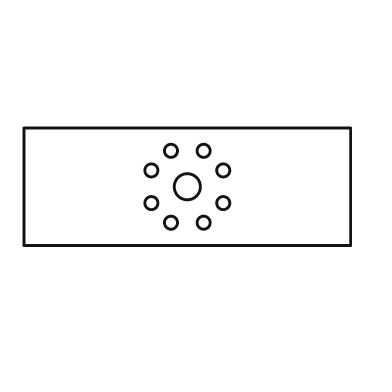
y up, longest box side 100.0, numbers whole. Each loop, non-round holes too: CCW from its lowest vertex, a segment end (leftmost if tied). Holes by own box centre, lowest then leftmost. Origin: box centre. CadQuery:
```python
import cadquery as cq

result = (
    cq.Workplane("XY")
    .moveTo(-50.0, -18.0)
    .lineTo(50.0, -18.0)
    .lineTo(50.0, 18.0)
    .lineTo(-50.0, 18.0)
    .close()
    .moveTo(-5.0, -11.0)
    .circle(2.0)
    .moveTo(5.0, -11.0)
    .circle(2.0)
    .moveTo(-11.0, -5.0)
    .circle(2.0)
    .moveTo(11.0, -5.0)
    .circle(2.0)
    .moveTo(0.0, 0.0)
    .circle(4.0)
    .moveTo(-11.0, 5.0)
    .circle(2.0)
    .moveTo(11.0, 5.0)
    .circle(2.0)
    .moveTo(-5.0, 11.0)
    .circle(2.0)
    .moveTo(5.0, 11.0)
    .circle(2.0)
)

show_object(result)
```